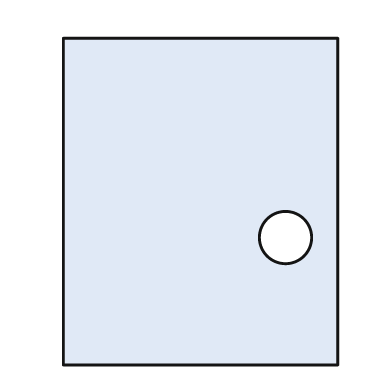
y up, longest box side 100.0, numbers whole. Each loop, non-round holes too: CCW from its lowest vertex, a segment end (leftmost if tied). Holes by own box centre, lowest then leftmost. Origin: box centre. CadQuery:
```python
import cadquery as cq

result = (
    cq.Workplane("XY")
    .moveTo(-42.0, -50.0)
    .lineTo(42.0, -50.0)
    .lineTo(42.0, 50.0)
    .lineTo(-42.0, 50.0)
    .close()
    .moveTo(26.0, -11.0)
    .circle(8.0)
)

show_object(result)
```